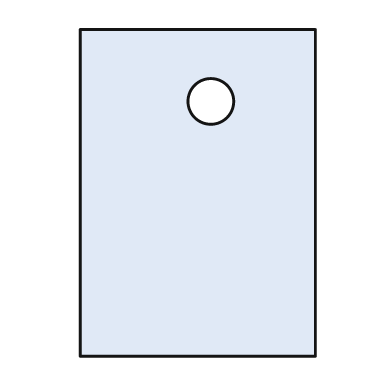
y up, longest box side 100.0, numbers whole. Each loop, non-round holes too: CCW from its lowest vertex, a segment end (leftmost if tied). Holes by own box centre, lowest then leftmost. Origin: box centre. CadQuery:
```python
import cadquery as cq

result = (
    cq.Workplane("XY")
    .moveTo(-36.0, -50.0)
    .lineTo(36.0, -50.0)
    .lineTo(36.0, 50.0)
    .lineTo(-36.0, 50.0)
    .close()
    .moveTo(4.0, 28.0)
    .circle(7.0)
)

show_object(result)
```